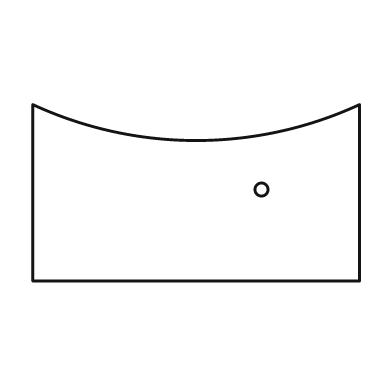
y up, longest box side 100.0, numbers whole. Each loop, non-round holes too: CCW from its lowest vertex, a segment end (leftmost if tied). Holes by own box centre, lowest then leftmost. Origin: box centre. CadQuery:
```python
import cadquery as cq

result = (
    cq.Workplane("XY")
    .moveTo(-50.0, -27.0)
    .lineTo(50.0, -27.0)
    .lineTo(50.0, 27.0)
    .threePointArc((0.0, 16.0), (-50.0, 27.0))
    .close()
    .moveTo(20.0, 1.0)
    .circle(2.0)
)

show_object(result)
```